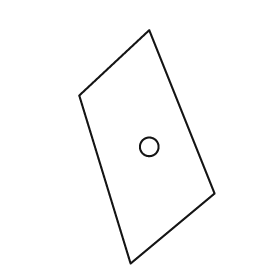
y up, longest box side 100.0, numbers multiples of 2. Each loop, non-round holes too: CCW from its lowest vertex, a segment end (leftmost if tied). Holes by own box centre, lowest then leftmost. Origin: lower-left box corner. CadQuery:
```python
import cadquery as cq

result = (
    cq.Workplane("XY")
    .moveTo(22.0, 0.0)
    .lineTo(58.0, 30.0)
    .lineTo(30.0, 100.0)
    .lineTo(0.0, 72.0)
    .close()
    .moveTo(30.0, 50.0)
    .circle(4.0)
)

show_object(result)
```